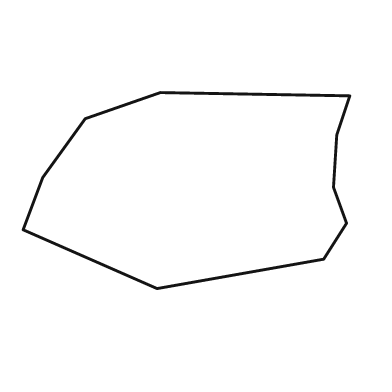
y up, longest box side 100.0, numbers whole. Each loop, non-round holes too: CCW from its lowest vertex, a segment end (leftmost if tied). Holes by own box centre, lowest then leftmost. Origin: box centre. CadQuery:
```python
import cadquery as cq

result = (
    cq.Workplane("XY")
    .moveTo(-9.0, -30.0)
    .lineTo(42.0, -21.0)
    .lineTo(49.0, -10.0)
    .lineTo(45.0, 1.0)
    .lineTo(46.0, 17.0)
    .lineTo(50.0, 29.0)
    .lineTo(-8.0, 30.0)
    .lineTo(-31.0, 22.0)
    .lineTo(-44.0, 4.0)
    .lineTo(-50.0, -12.0)
    .close()
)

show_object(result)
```